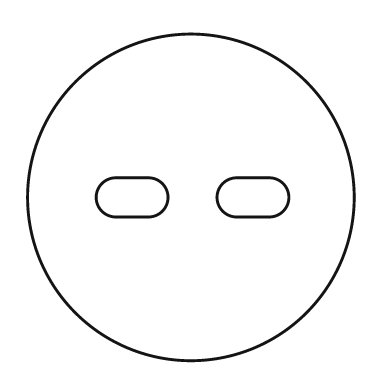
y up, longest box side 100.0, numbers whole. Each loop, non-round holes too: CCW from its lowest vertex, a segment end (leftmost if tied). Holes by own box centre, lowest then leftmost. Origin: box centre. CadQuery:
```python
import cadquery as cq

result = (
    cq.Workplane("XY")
    .moveTo(0.0, 0.0)
    .circle(50.0)
    .moveTo(-23.0, -6.0)
    .lineTo(-13.0, -6.0)
    .threePointArc((-7.0, 0.0), (-13.0, 6.0))
    .lineTo(-23.0, 6.0)
    .threePointArc((-29.0, 0.0), (-23.0, -6.0))
    .close()
    .moveTo(14.0, -6.0)
    .lineTo(24.0, -6.0)
    .threePointArc((30.0, 0.0), (24.0, 6.0))
    .lineTo(14.0, 6.0)
    .threePointArc((8.0, 0.0), (14.0, -6.0))
    .close()
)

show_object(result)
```